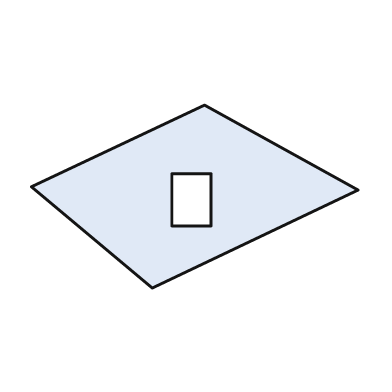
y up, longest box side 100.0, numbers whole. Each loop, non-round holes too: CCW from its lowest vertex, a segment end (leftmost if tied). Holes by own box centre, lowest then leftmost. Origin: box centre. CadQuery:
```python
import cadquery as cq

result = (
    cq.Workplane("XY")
    .moveTo(-13.0, -28.0)
    .lineTo(50.0, 2.0)
    .lineTo(3.0, 28.0)
    .lineTo(-50.0, 3.0)
    .close()
    .moveTo(-7.0, -9.0)
    .lineTo(5.0, -9.0)
    .lineTo(5.0, 7.0)
    .lineTo(-7.0, 7.0)
    .close()
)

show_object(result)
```